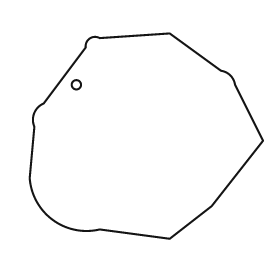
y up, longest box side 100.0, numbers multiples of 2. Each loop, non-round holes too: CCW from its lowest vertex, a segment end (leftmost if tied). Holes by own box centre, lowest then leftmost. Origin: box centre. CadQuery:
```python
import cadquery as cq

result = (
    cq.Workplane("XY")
    .moveTo(10.0, -44.0)
    .lineTo(28.0, -30.0)
    .lineTo(50.0, -2.0)
    .lineTo(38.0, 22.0)
    .threePointArc((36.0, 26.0), (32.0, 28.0))
    .lineTo(10.0, 44.0)
    .lineTo(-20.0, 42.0)
    .threePointArc((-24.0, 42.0), (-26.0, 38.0))
    .lineTo(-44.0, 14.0)
    .threePointArc((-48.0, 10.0), (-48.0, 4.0))
    .lineTo(-50.0, -18.0)
    .threePointArc((-40.0, -36.0), (-20.0, -40.0))
    .close()
    .moveTo(-30.0, 22.0)
    .circle(2.0)
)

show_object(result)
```